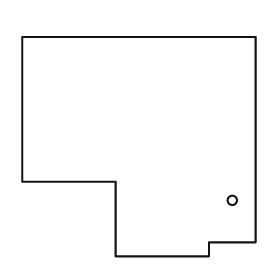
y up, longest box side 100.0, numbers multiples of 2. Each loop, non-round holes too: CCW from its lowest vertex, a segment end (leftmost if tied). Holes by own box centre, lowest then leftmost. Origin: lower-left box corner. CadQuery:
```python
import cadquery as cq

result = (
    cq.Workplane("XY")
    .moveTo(40.0, 0.0)
    .lineTo(80.0, 0.0)
    .lineTo(80.0, 6.0)
    .lineTo(100.0, 6.0)
    .lineTo(100.0, 94.0)
    .lineTo(0.0, 94.0)
    .lineTo(0.0, 32.0)
    .lineTo(40.0, 32.0)
    .close()
    .moveTo(90.0, 24.0)
    .circle(2.0)
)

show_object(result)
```